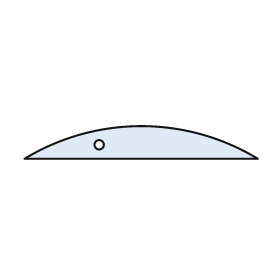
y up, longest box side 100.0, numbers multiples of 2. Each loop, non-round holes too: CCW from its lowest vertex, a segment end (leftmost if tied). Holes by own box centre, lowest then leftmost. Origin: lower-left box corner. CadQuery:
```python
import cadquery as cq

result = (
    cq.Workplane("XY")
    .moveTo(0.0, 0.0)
    .lineTo(100.0, 0.0)
    .threePointArc((50.0, 14.0), (0.0, 0.0))
    .close()
    .moveTo(32.0, 6.0)
    .circle(2.0)
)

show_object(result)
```